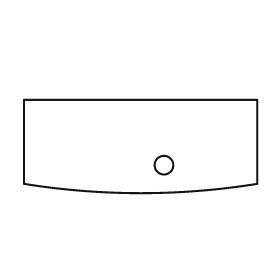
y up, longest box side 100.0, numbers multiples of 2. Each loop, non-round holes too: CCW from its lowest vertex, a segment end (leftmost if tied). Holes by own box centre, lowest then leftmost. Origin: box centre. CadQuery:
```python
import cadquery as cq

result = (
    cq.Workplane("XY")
    .moveTo(-50.0, -16.0)
    .threePointArc((0.0, -20.0), (50.0, -16.0))
    .lineTo(50.0, 20.0)
    .lineTo(-50.0, 20.0)
    .close()
    .moveTo(10.0, -8.0)
    .circle(4.0)
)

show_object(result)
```